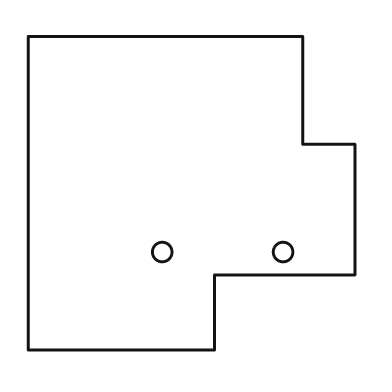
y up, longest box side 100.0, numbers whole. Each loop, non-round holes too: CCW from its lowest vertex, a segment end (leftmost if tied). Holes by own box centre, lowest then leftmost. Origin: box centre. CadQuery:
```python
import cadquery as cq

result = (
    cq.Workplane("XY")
    .moveTo(-50.0, -48.0)
    .lineTo(7.0, -48.0)
    .lineTo(7.0, -25.0)
    .lineTo(50.0, -25.0)
    .lineTo(50.0, 15.0)
    .lineTo(34.0, 15.0)
    .lineTo(34.0, 48.0)
    .lineTo(-50.0, 48.0)
    .close()
    .moveTo(-9.0, -18.0)
    .circle(3.0)
    .moveTo(28.0, -18.0)
    .circle(3.0)
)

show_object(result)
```